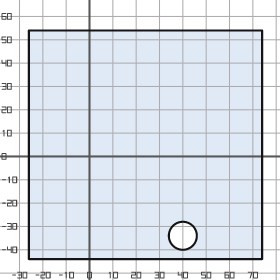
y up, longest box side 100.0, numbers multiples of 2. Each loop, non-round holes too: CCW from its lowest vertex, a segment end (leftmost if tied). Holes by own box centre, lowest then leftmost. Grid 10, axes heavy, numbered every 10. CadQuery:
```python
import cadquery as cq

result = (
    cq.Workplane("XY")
    .moveTo(-26.0, -44.0)
    .lineTo(74.0, -44.0)
    .lineTo(74.0, 54.0)
    .lineTo(-26.0, 54.0)
    .close()
    .moveTo(40.0, -34.0)
    .circle(6.0)
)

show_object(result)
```